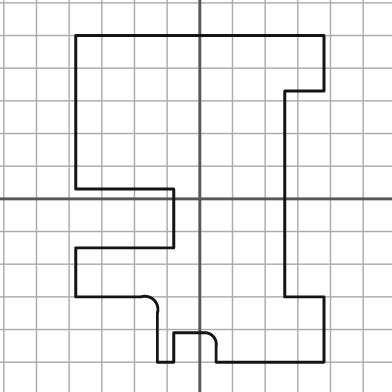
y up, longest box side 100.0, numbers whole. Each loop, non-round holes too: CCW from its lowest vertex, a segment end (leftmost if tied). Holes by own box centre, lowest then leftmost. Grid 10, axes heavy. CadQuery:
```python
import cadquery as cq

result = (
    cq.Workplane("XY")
    .moveTo(-13.0, -50.0)
    .lineTo(-8.0, -50.0)
    .lineTo(-8.0, -41.0)
    .lineTo(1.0, -41.0)
    .threePointArc((4.0, -42.0), (5.0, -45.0))
    .lineTo(5.0, -50.0)
    .lineTo(38.0, -50.0)
    .lineTo(38.0, -30.0)
    .lineTo(26.0, -30.0)
    .lineTo(26.0, 33.0)
    .lineTo(38.0, 33.0)
    .lineTo(38.0, 50.0)
    .lineTo(-38.0, 50.0)
    .lineTo(-38.0, 3.0)
    .lineTo(-8.0, 3.0)
    .lineTo(-8.0, -15.0)
    .lineTo(-38.0, -15.0)
    .lineTo(-38.0, -30.0)
    .lineTo(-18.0, -30.0)
    .threePointArc((-14.0, -31.0), (-13.0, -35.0))
    .close()
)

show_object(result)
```